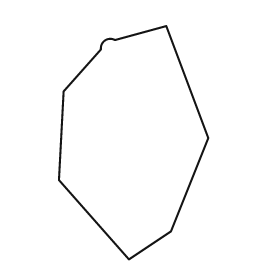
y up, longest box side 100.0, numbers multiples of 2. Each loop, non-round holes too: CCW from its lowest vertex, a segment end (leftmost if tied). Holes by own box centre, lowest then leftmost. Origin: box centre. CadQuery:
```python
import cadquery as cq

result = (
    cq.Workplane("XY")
    .moveTo(-2.0, -50.0)
    .lineTo(16.0, -38.0)
    .lineTo(32.0, 2.0)
    .lineTo(14.0, 50.0)
    .lineTo(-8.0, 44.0)
    .threePointArc((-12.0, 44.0), (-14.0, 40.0))
    .lineTo(-30.0, 22.0)
    .lineTo(-32.0, -16.0)
    .close()
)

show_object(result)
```